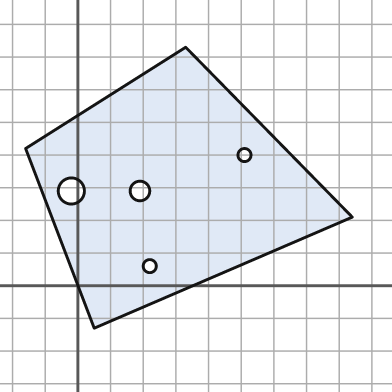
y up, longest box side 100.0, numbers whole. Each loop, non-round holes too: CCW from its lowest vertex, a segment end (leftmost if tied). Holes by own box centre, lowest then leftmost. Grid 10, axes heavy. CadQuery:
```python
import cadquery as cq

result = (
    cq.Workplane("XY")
    .moveTo(5.0, -13.0)
    .lineTo(84.0, 21.0)
    .lineTo(33.0, 73.0)
    .lineTo(-16.0, 42.0)
    .close()
    .moveTo(22.0, 6.0)
    .circle(2.0)
    .moveTo(-2.0, 29.0)
    .circle(4.0)
    .moveTo(19.0, 29.0)
    .circle(3.0)
    .moveTo(51.0, 40.0)
    .circle(2.0)
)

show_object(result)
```